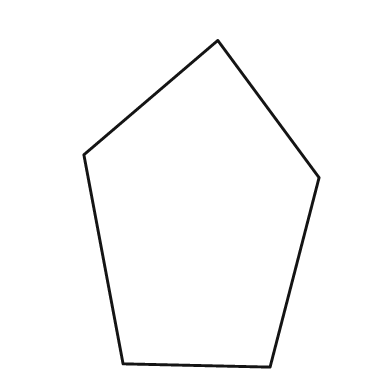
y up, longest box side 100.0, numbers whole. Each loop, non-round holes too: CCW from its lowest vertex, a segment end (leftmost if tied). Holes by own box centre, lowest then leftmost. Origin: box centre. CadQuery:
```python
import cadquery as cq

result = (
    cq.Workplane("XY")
    .moveTo(21.0, -50.0)
    .lineTo(36.0, 8.0)
    .lineTo(5.0, 50.0)
    .lineTo(-36.0, 15.0)
    .lineTo(-24.0, -49.0)
    .close()
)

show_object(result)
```